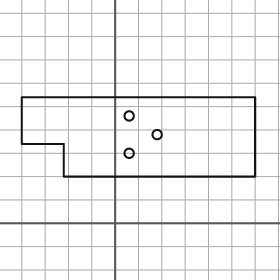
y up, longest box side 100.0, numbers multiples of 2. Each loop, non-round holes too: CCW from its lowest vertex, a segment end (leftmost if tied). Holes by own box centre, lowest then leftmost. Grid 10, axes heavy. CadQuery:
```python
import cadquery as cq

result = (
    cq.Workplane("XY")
    .moveTo(-22.0, 20.0)
    .lineTo(60.0, 20.0)
    .lineTo(60.0, 54.0)
    .lineTo(-40.0, 54.0)
    .lineTo(-40.0, 34.0)
    .lineTo(-22.0, 34.0)
    .close()
    .moveTo(6.0, 30.0)
    .circle(2.0)
    .moveTo(18.0, 38.0)
    .circle(2.0)
    .moveTo(6.0, 46.0)
    .circle(2.0)
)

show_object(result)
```